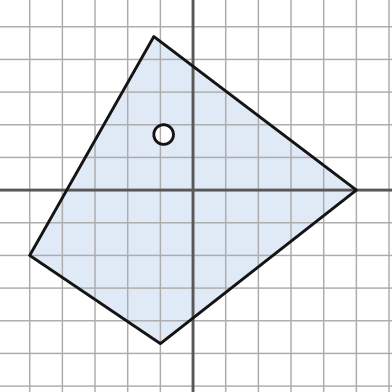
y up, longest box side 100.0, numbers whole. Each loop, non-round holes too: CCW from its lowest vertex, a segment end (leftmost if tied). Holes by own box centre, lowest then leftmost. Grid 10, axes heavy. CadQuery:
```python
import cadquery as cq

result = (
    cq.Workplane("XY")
    .moveTo(-10.0, -47.0)
    .lineTo(50.0, 0.0)
    .lineTo(-12.0, 47.0)
    .lineTo(-50.0, -20.0)
    .close()
    .moveTo(-9.0, 17.0)
    .circle(3.0)
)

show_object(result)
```